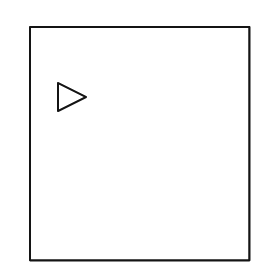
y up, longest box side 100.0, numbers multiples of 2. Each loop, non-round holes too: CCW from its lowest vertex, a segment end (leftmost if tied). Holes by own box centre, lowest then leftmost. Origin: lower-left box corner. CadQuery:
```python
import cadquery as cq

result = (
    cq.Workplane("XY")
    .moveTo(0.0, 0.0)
    .lineTo(94.0, 0.0)
    .lineTo(94.0, 100.0)
    .lineTo(0.0, 100.0)
    .close()
    .moveTo(12.0, 64.0)
    .lineTo(24.0, 70.0)
    .lineTo(12.0, 76.0)
    .close()
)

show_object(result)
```